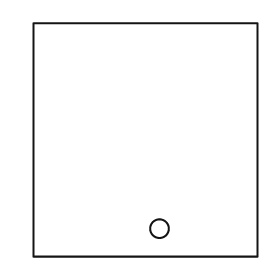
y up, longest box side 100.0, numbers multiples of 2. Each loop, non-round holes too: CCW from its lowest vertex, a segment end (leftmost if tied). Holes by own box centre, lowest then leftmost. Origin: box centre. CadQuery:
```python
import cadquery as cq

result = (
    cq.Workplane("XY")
    .moveTo(-48.0, -50.0)
    .lineTo(48.0, -50.0)
    .lineTo(48.0, 50.0)
    .lineTo(-48.0, 50.0)
    .close()
    .moveTo(6.0, -38.0)
    .circle(4.0)
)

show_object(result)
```